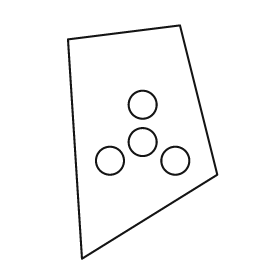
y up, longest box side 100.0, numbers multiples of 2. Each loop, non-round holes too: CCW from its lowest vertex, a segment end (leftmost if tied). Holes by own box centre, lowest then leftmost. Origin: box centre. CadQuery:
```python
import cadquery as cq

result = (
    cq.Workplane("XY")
    .moveTo(-26.0, -50.0)
    .lineTo(32.0, -14.0)
    .lineTo(16.0, 50.0)
    .lineTo(-32.0, 44.0)
    .close()
    .moveTo(-14.0, -8.0)
    .circle(6.0)
    .moveTo(14.0, -8.0)
    .circle(6.0)
    .moveTo(0.0, 0.0)
    .circle(6.0)
    .moveTo(0.0, 16.0)
    .circle(6.0)
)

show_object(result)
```